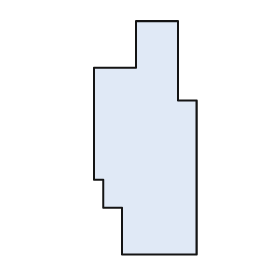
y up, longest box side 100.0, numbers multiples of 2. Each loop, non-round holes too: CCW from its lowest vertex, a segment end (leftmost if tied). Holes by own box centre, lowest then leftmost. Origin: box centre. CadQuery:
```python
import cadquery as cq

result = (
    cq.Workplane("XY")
    .moveTo(-10.0, -50.0)
    .lineTo(22.0, -50.0)
    .lineTo(22.0, 16.0)
    .lineTo(14.0, 16.0)
    .lineTo(14.0, 50.0)
    .lineTo(-4.0, 50.0)
    .lineTo(-4.0, 30.0)
    .lineTo(-22.0, 30.0)
    .lineTo(-22.0, -18.0)
    .lineTo(-18.0, -18.0)
    .lineTo(-18.0, -30.0)
    .lineTo(-10.0, -30.0)
    .close()
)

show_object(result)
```